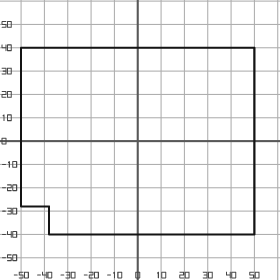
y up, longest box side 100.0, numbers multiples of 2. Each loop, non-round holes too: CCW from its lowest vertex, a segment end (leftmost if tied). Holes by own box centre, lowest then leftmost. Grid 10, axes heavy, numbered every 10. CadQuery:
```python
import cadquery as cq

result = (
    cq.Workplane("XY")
    .moveTo(-38.0, -40.0)
    .lineTo(50.0, -40.0)
    .lineTo(50.0, 40.0)
    .lineTo(-50.0, 40.0)
    .lineTo(-50.0, -28.0)
    .lineTo(-38.0, -28.0)
    .close()
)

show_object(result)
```